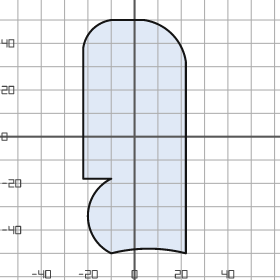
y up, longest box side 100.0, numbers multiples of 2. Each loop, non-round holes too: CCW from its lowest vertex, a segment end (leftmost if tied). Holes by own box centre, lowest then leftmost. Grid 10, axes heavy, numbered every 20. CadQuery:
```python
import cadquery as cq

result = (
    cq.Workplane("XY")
    .moveTo(-10.0, -50.0)
    .threePointArc((6.0, -48.0), (22.0, -50.0))
    .lineTo(22.0, 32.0)
    .threePointArc((16.0, 44.0), (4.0, 50.0))
    .lineTo(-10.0, 50.0)
    .threePointArc((-18.0, 46.0), (-22.0, 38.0))
    .lineTo(-22.0, -18.0)
    .lineTo(-10.0, -18.0)
    .threePointArc((-20.0, -34.0), (-10.0, -50.0))
    .close()
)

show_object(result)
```